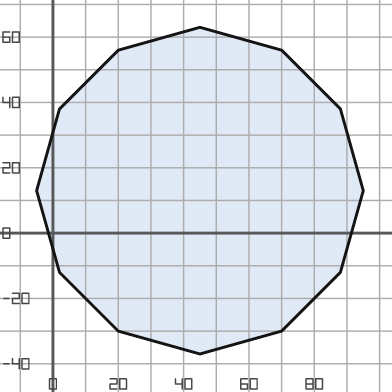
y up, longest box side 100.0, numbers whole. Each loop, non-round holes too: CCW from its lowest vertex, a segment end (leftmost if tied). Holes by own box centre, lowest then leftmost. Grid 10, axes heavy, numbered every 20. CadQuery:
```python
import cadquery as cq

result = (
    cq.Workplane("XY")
    .moveTo(45.0, -37.0)
    .lineTo(70.0, -30.0)
    .lineTo(88.0, -12.0)
    .lineTo(95.0, 13.0)
    .lineTo(88.0, 38.0)
    .lineTo(70.0, 56.0)
    .lineTo(45.0, 63.0)
    .lineTo(20.0, 56.0)
    .lineTo(2.0, 38.0)
    .lineTo(-5.0, 13.0)
    .lineTo(2.0, -12.0)
    .lineTo(20.0, -30.0)
    .close()
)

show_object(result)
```